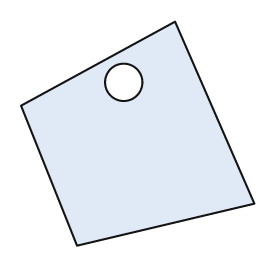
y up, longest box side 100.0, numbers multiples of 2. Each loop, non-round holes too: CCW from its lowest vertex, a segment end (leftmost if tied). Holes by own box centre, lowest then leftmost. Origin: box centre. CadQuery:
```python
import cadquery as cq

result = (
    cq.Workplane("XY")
    .moveTo(-26.0, -48.0)
    .lineTo(50.0, -30.0)
    .lineTo(16.0, 48.0)
    .lineTo(-50.0, 12.0)
    .close()
    .moveTo(-6.0, 22.0)
    .circle(8.0)
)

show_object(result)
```